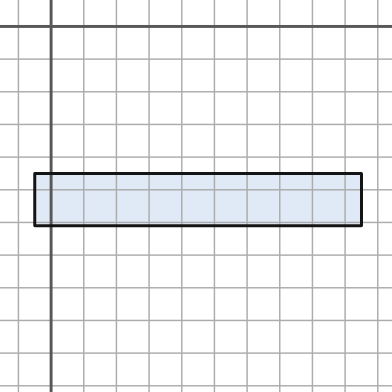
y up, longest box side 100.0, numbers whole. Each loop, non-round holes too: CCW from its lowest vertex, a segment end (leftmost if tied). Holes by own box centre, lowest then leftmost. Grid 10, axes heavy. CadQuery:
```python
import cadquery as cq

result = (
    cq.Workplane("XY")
    .moveTo(-5.0, -61.0)
    .lineTo(95.0, -61.0)
    .lineTo(95.0, -45.0)
    .lineTo(-5.0, -45.0)
    .close()
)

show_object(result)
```